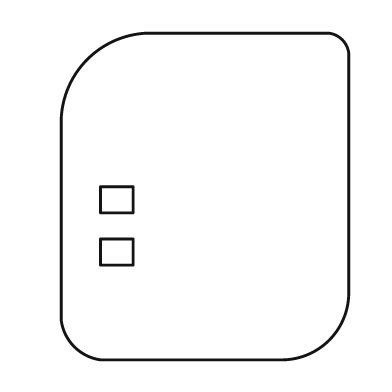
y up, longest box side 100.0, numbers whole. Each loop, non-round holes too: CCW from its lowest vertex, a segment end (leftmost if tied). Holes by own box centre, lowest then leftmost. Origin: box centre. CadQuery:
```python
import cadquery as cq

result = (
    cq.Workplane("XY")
    .moveTo(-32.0, -50.0)
    .lineTo(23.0, -50.0)
    .threePointArc((38.0, -44.0), (44.0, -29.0))
    .lineTo(44.0, 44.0)
    .threePointArc((42.0, 48.0), (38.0, 50.0))
    .lineTo(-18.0, 50.0)
    .threePointArc((-36.0, 42.0), (-44.0, 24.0))
    .lineTo(-44.0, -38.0)
    .threePointArc((-40.0, -46.0), (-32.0, -50.0))
    .close()
    .moveTo(-32.0, -21.0)
    .lineTo(-22.0, -21.0)
    .lineTo(-22.0, -13.0)
    .lineTo(-32.0, -13.0)
    .close()
    .moveTo(-32.0, -5.0)
    .lineTo(-22.0, -5.0)
    .lineTo(-22.0, 3.0)
    .lineTo(-32.0, 3.0)
    .close()
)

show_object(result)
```